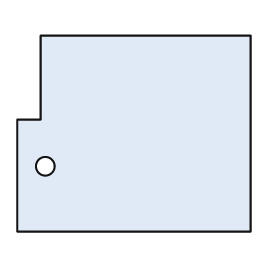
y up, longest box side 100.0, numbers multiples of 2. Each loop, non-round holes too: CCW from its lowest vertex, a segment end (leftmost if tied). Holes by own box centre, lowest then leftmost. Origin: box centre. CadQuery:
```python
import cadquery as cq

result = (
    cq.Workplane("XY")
    .moveTo(-50.0, -42.0)
    .lineTo(50.0, -42.0)
    .lineTo(50.0, 42.0)
    .lineTo(-40.0, 42.0)
    .lineTo(-40.0, 6.0)
    .lineTo(-50.0, 6.0)
    .close()
    .moveTo(-38.0, -14.0)
    .circle(4.0)
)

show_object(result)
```